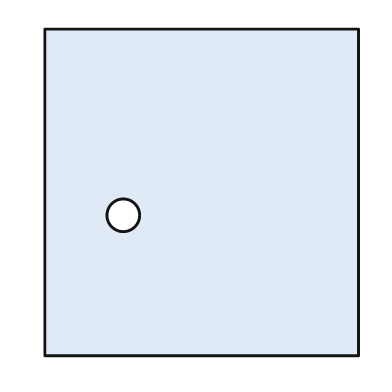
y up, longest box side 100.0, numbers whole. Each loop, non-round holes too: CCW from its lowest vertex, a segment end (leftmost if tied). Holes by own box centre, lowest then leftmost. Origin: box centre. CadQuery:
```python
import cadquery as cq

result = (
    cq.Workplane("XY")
    .moveTo(-48.0, -50.0)
    .lineTo(48.0, -50.0)
    .lineTo(48.0, 50.0)
    .lineTo(-48.0, 50.0)
    .close()
    .moveTo(-24.0, -7.0)
    .circle(5.0)
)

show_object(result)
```